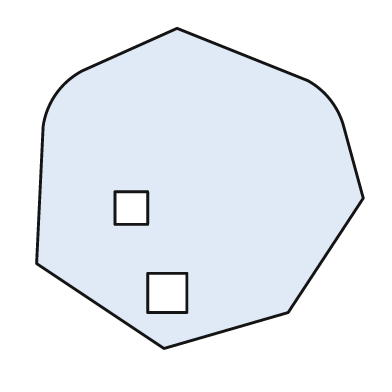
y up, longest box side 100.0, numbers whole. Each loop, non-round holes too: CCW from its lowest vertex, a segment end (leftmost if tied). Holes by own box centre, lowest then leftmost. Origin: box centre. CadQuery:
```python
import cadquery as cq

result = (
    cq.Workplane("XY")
    .moveTo(-11.0, -49.0)
    .lineTo(27.0, -38.0)
    .lineTo(50.0, -3.0)
    .lineTo(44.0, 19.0)
    .threePointArc((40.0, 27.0), (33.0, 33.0))
    .lineTo(-7.0, 49.0)
    .lineTo(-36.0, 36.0)
    .threePointArc((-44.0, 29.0), (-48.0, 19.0))
    .lineTo(-50.0, -23.0)
    .close()
    .moveTo(-16.0, -38.0)
    .lineTo(-4.0, -38.0)
    .lineTo(-4.0, -26.0)
    .lineTo(-16.0, -26.0)
    .close()
    .moveTo(-26.0, -11.0)
    .lineTo(-16.0, -11.0)
    .lineTo(-16.0, -1.0)
    .lineTo(-26.0, -1.0)
    .close()
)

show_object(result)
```